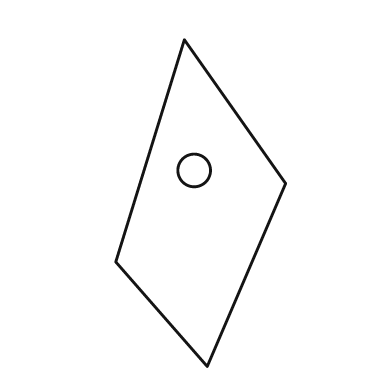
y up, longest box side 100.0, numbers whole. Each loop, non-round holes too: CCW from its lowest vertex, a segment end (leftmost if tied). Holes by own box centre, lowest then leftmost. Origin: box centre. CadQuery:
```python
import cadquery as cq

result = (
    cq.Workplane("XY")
    .moveTo(2.0, -50.0)
    .lineTo(26.0, 6.0)
    .lineTo(-5.0, 50.0)
    .lineTo(-26.0, -18.0)
    .close()
    .moveTo(-2.0, 10.0)
    .circle(5.0)
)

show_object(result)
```